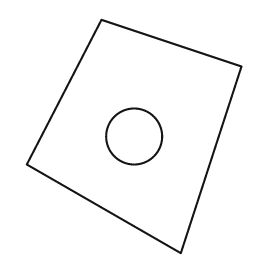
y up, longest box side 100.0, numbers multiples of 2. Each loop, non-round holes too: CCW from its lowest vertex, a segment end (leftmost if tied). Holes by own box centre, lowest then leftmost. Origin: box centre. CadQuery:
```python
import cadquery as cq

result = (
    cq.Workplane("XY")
    .moveTo(20.0, -50.0)
    .lineTo(46.0, 30.0)
    .lineTo(-14.0, 50.0)
    .lineTo(-46.0, -12.0)
    .close()
    .moveTo(0.0, 0.0)
    .circle(12.0)
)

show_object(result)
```